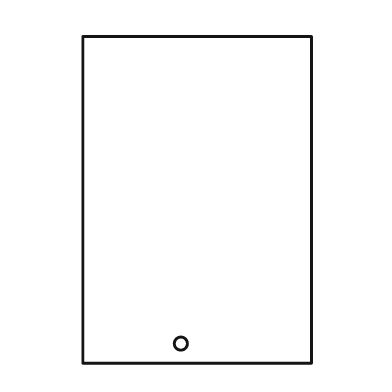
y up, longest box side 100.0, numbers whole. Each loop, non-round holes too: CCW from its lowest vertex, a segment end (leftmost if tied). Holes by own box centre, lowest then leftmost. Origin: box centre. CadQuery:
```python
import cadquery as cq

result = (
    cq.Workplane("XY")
    .moveTo(-35.0, -50.0)
    .lineTo(35.0, -50.0)
    .lineTo(35.0, 50.0)
    .lineTo(-35.0, 50.0)
    .close()
    .moveTo(-5.0, -44.0)
    .circle(2.0)
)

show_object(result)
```